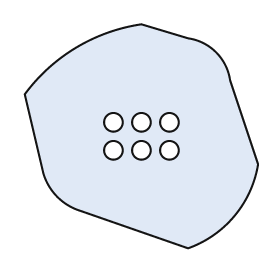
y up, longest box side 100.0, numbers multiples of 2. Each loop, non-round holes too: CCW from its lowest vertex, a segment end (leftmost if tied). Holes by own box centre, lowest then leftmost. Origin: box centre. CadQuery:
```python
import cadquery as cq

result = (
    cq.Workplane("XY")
    .moveTo(20.0, -48.0)
    .threePointArc((40.0, -34.0), (50.0, -12.0))
    .lineTo(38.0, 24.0)
    .threePointArc((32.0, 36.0), (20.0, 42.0))
    .lineTo(0.0, 48.0)
    .threePointArc((-28.0, 38.0), (-50.0, 18.0))
    .lineTo(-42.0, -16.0)
    .threePointArc((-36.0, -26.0), (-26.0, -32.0))
    .close()
    .moveTo(-12.0, -6.0)
    .circle(4.0)
    .moveTo(0.0, -6.0)
    .circle(4.0)
    .moveTo(12.0, -6.0)
    .circle(4.0)
    .moveTo(-12.0, 6.0)
    .circle(4.0)
    .moveTo(0.0, 6.0)
    .circle(4.0)
    .moveTo(12.0, 6.0)
    .circle(4.0)
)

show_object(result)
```